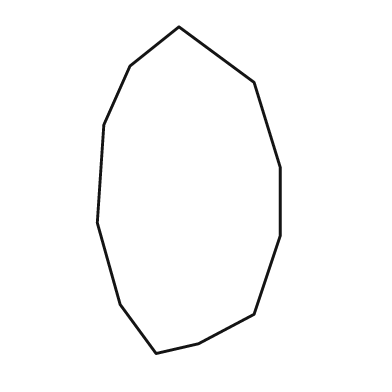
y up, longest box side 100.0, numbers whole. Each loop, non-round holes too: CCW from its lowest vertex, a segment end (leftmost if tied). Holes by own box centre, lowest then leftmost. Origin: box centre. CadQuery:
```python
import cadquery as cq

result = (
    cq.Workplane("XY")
    .moveTo(-10.0, -50.0)
    .lineTo(3.0, -47.0)
    .lineTo(20.0, -38.0)
    .lineTo(28.0, -14.0)
    .lineTo(28.0, 7.0)
    .lineTo(20.0, 33.0)
    .lineTo(-3.0, 50.0)
    .lineTo(-18.0, 38.0)
    .lineTo(-26.0, 20.0)
    .lineTo(-28.0, -10.0)
    .lineTo(-21.0, -35.0)
    .close()
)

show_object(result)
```